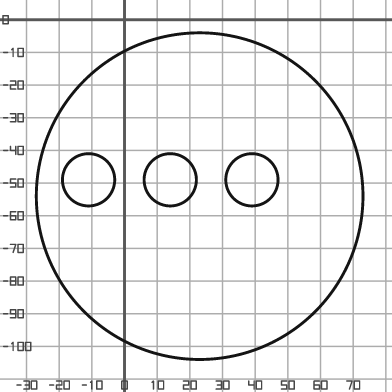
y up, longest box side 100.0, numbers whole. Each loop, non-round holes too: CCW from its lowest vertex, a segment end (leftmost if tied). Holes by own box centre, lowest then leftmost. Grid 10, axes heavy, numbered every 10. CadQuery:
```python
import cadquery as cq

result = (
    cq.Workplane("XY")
    .moveTo(23.0, -54.0)
    .circle(50.0)
    .moveTo(-11.0, -49.0)
    .circle(8.0)
    .moveTo(14.0, -49.0)
    .circle(8.0)
    .moveTo(39.0, -49.0)
    .circle(8.0)
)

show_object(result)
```